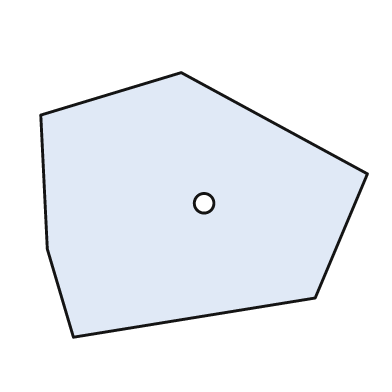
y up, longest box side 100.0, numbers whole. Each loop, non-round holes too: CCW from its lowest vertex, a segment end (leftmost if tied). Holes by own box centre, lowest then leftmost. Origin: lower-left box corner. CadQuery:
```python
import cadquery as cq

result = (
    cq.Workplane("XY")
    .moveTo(10.0, 0.0)
    .lineTo(84.0, 12.0)
    .lineTo(100.0, 50.0)
    .lineTo(43.0, 81.0)
    .lineTo(0.0, 68.0)
    .lineTo(2.0, 27.0)
    .close()
    .moveTo(50.0, 41.0)
    .circle(3.0)
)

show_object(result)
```